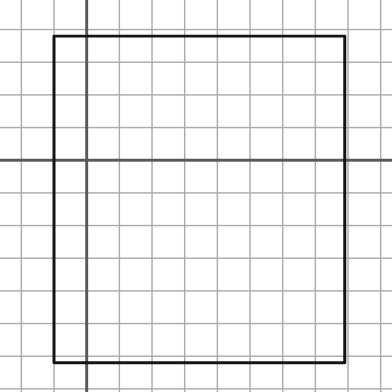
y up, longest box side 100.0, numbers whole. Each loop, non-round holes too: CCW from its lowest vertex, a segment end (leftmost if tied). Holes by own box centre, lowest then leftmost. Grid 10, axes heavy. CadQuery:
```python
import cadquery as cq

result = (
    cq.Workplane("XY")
    .moveTo(-10.0, -62.0)
    .lineTo(79.0, -62.0)
    .lineTo(79.0, 38.0)
    .lineTo(-10.0, 38.0)
    .close()
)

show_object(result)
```